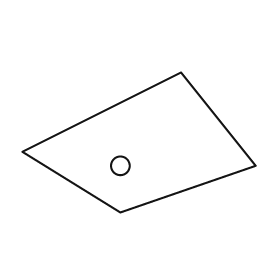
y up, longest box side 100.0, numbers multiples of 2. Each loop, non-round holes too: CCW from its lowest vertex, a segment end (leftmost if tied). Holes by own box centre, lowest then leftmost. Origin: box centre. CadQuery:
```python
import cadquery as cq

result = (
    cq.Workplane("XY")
    .moveTo(-8.0, -30.0)
    .lineTo(50.0, -10.0)
    .lineTo(18.0, 30.0)
    .lineTo(-50.0, -4.0)
    .close()
    .moveTo(-8.0, -10.0)
    .circle(4.0)
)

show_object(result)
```